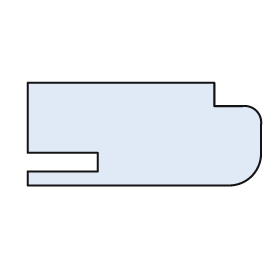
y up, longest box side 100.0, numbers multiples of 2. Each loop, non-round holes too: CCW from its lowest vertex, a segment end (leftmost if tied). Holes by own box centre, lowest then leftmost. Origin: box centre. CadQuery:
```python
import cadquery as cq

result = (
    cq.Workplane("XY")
    .moveTo(-50.0, -22.0)
    .lineTo(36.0, -22.0)
    .threePointArc((46.0, -18.0), (50.0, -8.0))
    .lineTo(50.0, 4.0)
    .threePointArc((48.0, 10.0), (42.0, 12.0))
    .lineTo(30.0, 12.0)
    .lineTo(30.0, 22.0)
    .lineTo(-50.0, 22.0)
    .lineTo(-50.0, -8.0)
    .lineTo(-20.0, -8.0)
    .lineTo(-20.0, -16.0)
    .lineTo(-50.0, -16.0)
    .close()
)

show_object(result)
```